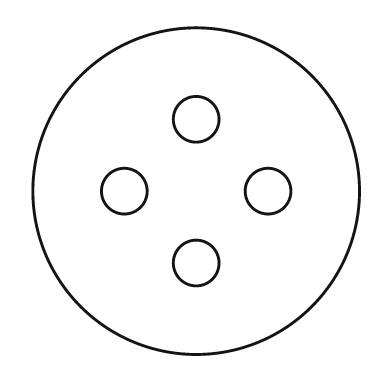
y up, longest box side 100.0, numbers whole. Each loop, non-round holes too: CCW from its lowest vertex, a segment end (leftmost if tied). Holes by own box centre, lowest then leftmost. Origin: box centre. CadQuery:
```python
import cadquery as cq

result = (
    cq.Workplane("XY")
    .moveTo(0.0, 0.0)
    .circle(50.0)
    .moveTo(0.0, -22.0)
    .circle(7.0)
    .moveTo(-22.0, 0.0)
    .circle(7.0)
    .moveTo(22.0, 0.0)
    .circle(7.0)
    .moveTo(0.0, 22.0)
    .circle(7.0)
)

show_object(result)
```